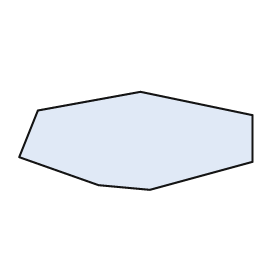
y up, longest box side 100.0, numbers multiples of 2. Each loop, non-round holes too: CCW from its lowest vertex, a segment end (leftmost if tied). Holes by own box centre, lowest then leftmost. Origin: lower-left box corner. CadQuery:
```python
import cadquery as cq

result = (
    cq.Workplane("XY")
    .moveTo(56.0, 0.0)
    .lineTo(100.0, 12.0)
    .lineTo(100.0, 32.0)
    .lineTo(52.0, 42.0)
    .lineTo(8.0, 34.0)
    .lineTo(0.0, 14.0)
    .lineTo(34.0, 2.0)
    .close()
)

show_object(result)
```